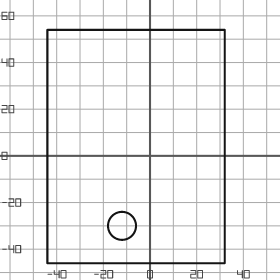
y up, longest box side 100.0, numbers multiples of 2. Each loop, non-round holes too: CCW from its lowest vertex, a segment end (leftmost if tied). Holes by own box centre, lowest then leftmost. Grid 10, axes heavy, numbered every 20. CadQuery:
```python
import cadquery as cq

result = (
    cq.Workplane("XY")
    .moveTo(-44.0, -46.0)
    .lineTo(32.0, -46.0)
    .lineTo(32.0, 54.0)
    .lineTo(-44.0, 54.0)
    .close()
    .moveTo(-12.0, -30.0)
    .circle(6.0)
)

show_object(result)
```